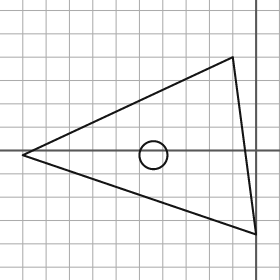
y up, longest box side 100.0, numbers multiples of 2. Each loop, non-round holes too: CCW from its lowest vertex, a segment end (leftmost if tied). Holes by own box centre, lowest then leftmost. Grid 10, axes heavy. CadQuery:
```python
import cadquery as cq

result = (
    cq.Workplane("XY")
    .moveTo(0.0, -36.0)
    .lineTo(-10.0, 40.0)
    .lineTo(-100.0, -2.0)
    .close()
    .moveTo(-44.0, -2.0)
    .circle(6.0)
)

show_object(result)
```